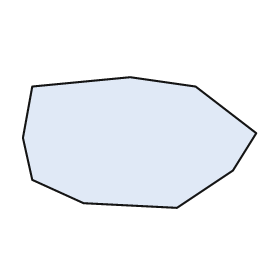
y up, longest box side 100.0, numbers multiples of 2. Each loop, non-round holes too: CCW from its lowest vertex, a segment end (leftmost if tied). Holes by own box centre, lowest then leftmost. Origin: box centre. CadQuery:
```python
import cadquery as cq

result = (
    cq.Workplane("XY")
    .moveTo(16.0, -28.0)
    .lineTo(40.0, -12.0)
    .lineTo(50.0, 4.0)
    .lineTo(24.0, 24.0)
    .lineTo(-4.0, 28.0)
    .lineTo(-46.0, 24.0)
    .lineTo(-50.0, 2.0)
    .lineTo(-46.0, -16.0)
    .lineTo(-24.0, -26.0)
    .close()
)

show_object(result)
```